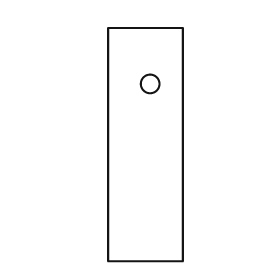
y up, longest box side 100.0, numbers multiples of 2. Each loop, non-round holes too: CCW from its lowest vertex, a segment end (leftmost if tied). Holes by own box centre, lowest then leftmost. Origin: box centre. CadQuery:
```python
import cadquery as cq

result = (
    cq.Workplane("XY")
    .moveTo(-16.0, -50.0)
    .lineTo(16.0, -50.0)
    .lineTo(16.0, 50.0)
    .lineTo(-16.0, 50.0)
    .close()
    .moveTo(2.0, 26.0)
    .circle(4.0)
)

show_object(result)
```